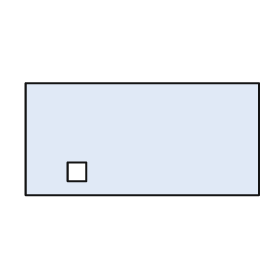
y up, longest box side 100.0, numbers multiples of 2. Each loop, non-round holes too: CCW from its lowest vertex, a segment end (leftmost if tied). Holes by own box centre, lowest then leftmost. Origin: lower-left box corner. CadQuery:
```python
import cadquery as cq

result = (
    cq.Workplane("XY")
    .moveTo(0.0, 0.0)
    .lineTo(100.0, 0.0)
    .lineTo(100.0, 48.0)
    .lineTo(0.0, 48.0)
    .close()
    .moveTo(18.0, 6.0)
    .lineTo(26.0, 6.0)
    .lineTo(26.0, 14.0)
    .lineTo(18.0, 14.0)
    .close()
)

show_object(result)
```